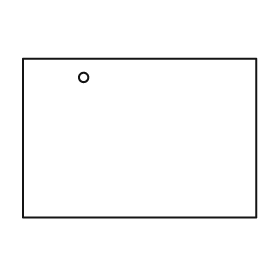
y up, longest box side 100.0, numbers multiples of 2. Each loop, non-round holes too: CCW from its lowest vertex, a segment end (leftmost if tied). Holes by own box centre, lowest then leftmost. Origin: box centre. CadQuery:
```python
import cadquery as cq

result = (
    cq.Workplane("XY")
    .moveTo(-50.0, -34.0)
    .lineTo(50.0, -34.0)
    .lineTo(50.0, 34.0)
    .lineTo(-50.0, 34.0)
    .close()
    .moveTo(-24.0, 26.0)
    .circle(2.0)
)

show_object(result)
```